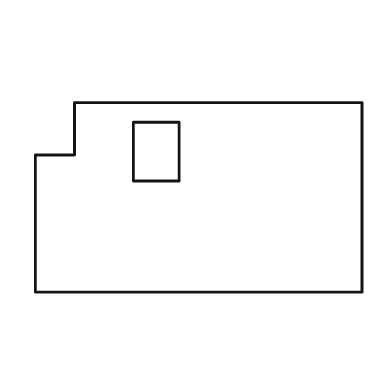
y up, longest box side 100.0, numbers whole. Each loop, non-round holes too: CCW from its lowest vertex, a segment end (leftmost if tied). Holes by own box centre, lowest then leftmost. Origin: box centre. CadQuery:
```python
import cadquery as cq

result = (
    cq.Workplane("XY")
    .moveTo(-50.0, -29.0)
    .lineTo(50.0, -29.0)
    .lineTo(50.0, 29.0)
    .lineTo(-38.0, 29.0)
    .lineTo(-38.0, 13.0)
    .lineTo(-50.0, 13.0)
    .close()
    .moveTo(-20.0, 5.0)
    .lineTo(-6.0, 5.0)
    .lineTo(-6.0, 23.0)
    .lineTo(-20.0, 23.0)
    .close()
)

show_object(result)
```